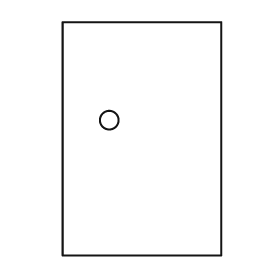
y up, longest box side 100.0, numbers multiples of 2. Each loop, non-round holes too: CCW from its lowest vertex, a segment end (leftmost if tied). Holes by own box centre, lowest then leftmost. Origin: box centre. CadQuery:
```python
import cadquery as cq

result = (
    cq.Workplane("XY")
    .moveTo(-34.0, -50.0)
    .lineTo(34.0, -50.0)
    .lineTo(34.0, 50.0)
    .lineTo(-34.0, 50.0)
    .close()
    .moveTo(-14.0, 8.0)
    .circle(4.0)
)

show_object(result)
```